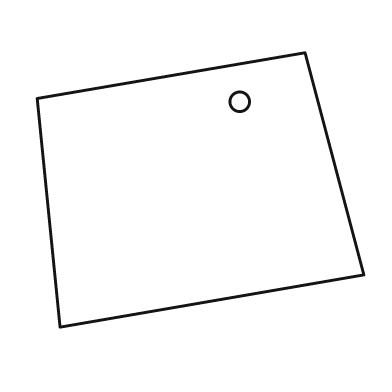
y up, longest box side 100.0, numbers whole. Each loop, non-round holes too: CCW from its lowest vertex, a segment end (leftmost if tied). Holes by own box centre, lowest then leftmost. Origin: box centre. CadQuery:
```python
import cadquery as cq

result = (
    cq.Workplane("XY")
    .moveTo(-43.0, -42.0)
    .lineTo(50.0, -26.0)
    .lineTo(32.0, 42.0)
    .lineTo(-50.0, 28.0)
    .close()
    .moveTo(12.0, 27.0)
    .circle(3.0)
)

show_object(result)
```